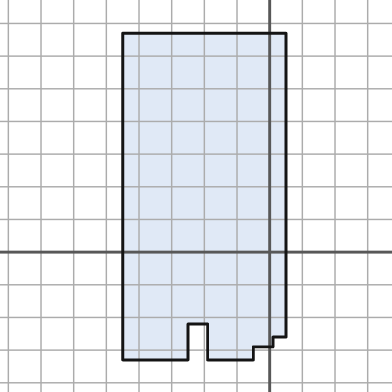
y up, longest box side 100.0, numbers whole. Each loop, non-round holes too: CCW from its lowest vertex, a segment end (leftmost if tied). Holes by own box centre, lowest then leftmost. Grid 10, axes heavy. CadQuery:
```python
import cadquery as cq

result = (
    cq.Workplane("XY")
    .moveTo(-45.0, -33.0)
    .lineTo(-25.0, -33.0)
    .lineTo(-25.0, -22.0)
    .lineTo(-19.0, -22.0)
    .lineTo(-19.0, -33.0)
    .lineTo(-5.0, -33.0)
    .lineTo(-5.0, -29.0)
    .lineTo(1.0, -29.0)
    .lineTo(1.0, -26.0)
    .lineTo(5.0, -26.0)
    .lineTo(5.0, 67.0)
    .lineTo(-45.0, 67.0)
    .close()
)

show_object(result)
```